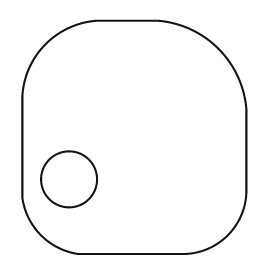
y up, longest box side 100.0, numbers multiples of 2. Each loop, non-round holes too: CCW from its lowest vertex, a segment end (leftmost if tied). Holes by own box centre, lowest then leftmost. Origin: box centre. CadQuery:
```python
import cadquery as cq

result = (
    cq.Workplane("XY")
    .moveTo(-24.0, -50.0)
    .lineTo(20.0, -50.0)
    .threePointArc((40.0, -42.0), (48.0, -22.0))
    .lineTo(48.0, 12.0)
    .threePointArc((36.0, 38.0), (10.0, 50.0))
    .lineTo(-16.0, 50.0)
    .threePointArc((-38.0, 40.0), (-48.0, 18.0))
    .lineTo(-48.0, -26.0)
    .threePointArc((-40.0, -42.0), (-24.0, -50.0))
    .close()
    .moveTo(-28.0, -18.0)
    .circle(12.0)
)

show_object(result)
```